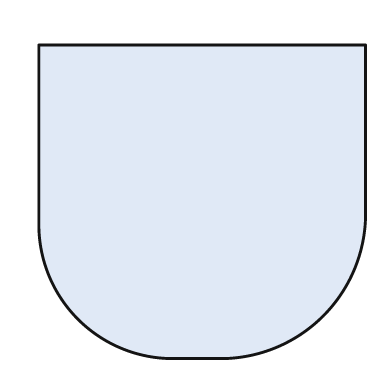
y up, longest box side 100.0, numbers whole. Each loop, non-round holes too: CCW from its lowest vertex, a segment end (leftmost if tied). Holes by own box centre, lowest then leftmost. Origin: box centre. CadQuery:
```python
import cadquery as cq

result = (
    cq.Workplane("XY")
    .moveTo(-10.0, -48.0)
    .lineTo(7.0, -48.0)
    .threePointArc((37.0, -35.0), (50.0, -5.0))
    .lineTo(50.0, 48.0)
    .lineTo(-50.0, 48.0)
    .lineTo(-50.0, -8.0)
    .threePointArc((-38.0, -36.0), (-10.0, -48.0))
    .close()
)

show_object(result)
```